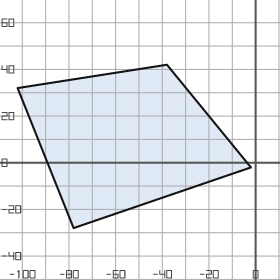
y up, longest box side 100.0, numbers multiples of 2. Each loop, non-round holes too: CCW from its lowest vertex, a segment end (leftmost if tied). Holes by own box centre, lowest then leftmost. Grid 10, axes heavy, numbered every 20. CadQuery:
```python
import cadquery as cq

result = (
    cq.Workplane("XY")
    .moveTo(-78.0, -28.0)
    .lineTo(-2.0, -2.0)
    .lineTo(-38.0, 42.0)
    .lineTo(-102.0, 32.0)
    .close()
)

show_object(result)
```